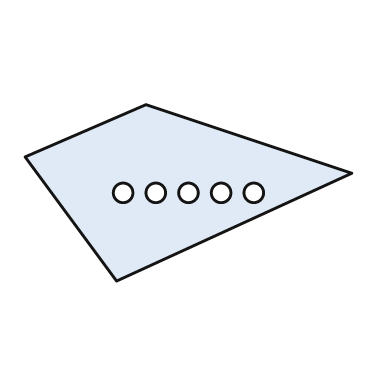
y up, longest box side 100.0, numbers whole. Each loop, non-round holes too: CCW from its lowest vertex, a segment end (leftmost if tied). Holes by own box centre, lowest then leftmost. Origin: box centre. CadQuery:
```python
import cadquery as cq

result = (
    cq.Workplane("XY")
    .moveTo(-22.0, -27.0)
    .lineTo(50.0, 6.0)
    .lineTo(-13.0, 27.0)
    .lineTo(-50.0, 11.0)
    .close()
    .moveTo(-20.0, 0.0)
    .circle(3.0)
    .moveTo(-10.0, 0.0)
    .circle(3.0)
    .moveTo(0.0, 0.0)
    .circle(3.0)
    .moveTo(10.0, 0.0)
    .circle(3.0)
    .moveTo(20.0, 0.0)
    .circle(3.0)
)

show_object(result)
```